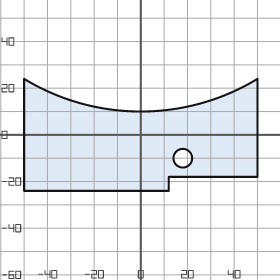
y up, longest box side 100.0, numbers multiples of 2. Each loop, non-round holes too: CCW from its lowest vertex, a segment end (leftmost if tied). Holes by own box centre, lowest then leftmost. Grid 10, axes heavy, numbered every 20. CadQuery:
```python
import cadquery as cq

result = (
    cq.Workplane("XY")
    .moveTo(-50.0, -24.0)
    .lineTo(12.0, -24.0)
    .lineTo(12.0, -18.0)
    .lineTo(50.0, -18.0)
    .lineTo(50.0, 24.0)
    .threePointArc((0.0, 10.0), (-50.0, 24.0))
    .close()
    .moveTo(18.0, -10.0)
    .circle(4.0)
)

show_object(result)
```